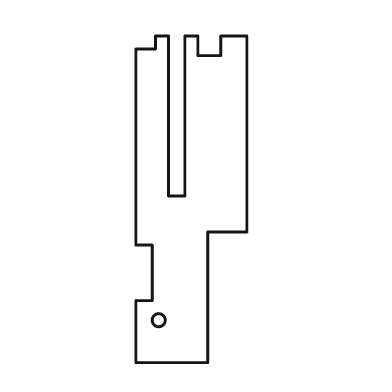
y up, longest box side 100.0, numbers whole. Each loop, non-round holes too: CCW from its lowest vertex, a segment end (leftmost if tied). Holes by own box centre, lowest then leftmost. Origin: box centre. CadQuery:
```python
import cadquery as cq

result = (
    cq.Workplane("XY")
    .moveTo(-17.0, -50.0)
    .lineTo(5.0, -50.0)
    .lineTo(5.0, -10.0)
    .lineTo(17.0, -10.0)
    .lineTo(17.0, 50.0)
    .lineTo(9.0, 50.0)
    .lineTo(9.0, 44.0)
    .lineTo(2.0, 44.0)
    .lineTo(2.0, 50.0)
    .lineTo(-2.0, 50.0)
    .lineTo(-2.0, 1.0)
    .lineTo(-7.0, 1.0)
    .lineTo(-7.0, 50.0)
    .lineTo(-11.0, 50.0)
    .lineTo(-11.0, 46.0)
    .lineTo(-17.0, 46.0)
    .lineTo(-17.0, -14.0)
    .lineTo(-12.0, -14.0)
    .lineTo(-12.0, -31.0)
    .lineTo(-17.0, -31.0)
    .close()
    .moveTo(-10.0, -37.0)
    .circle(2.0)
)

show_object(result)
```